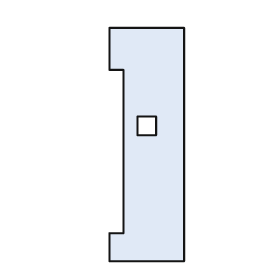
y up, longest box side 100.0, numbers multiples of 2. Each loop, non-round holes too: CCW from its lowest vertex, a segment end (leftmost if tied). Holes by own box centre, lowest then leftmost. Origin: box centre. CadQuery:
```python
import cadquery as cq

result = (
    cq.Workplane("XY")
    .moveTo(-16.0, -50.0)
    .lineTo(16.0, -50.0)
    .lineTo(16.0, 50.0)
    .lineTo(-16.0, 50.0)
    .lineTo(-16.0, 32.0)
    .lineTo(-10.0, 32.0)
    .lineTo(-10.0, -38.0)
    .lineTo(-16.0, -38.0)
    .close()
    .moveTo(-4.0, 4.0)
    .lineTo(4.0, 4.0)
    .lineTo(4.0, 12.0)
    .lineTo(-4.0, 12.0)
    .close()
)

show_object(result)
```